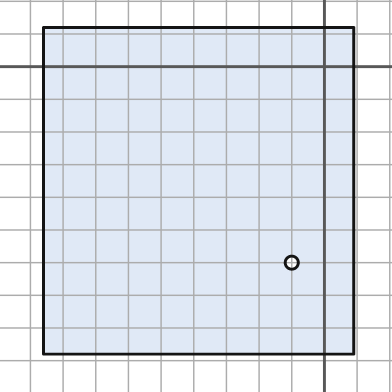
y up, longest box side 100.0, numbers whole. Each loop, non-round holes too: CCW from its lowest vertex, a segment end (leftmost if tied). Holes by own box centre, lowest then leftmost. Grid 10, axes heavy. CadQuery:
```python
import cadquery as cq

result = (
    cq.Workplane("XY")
    .moveTo(-86.0, -88.0)
    .lineTo(9.0, -88.0)
    .lineTo(9.0, 12.0)
    .lineTo(-86.0, 12.0)
    .close()
    .moveTo(-10.0, -60.0)
    .circle(2.0)
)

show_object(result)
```